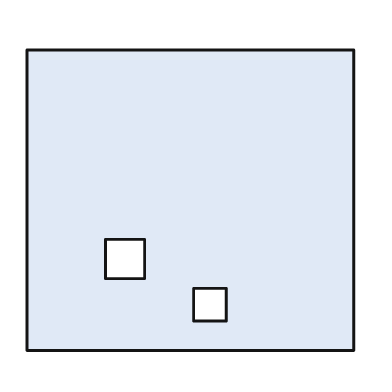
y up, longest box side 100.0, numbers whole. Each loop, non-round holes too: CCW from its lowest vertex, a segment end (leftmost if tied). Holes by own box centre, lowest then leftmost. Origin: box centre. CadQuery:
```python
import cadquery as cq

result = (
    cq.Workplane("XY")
    .moveTo(-50.0, -46.0)
    .lineTo(50.0, -46.0)
    .lineTo(50.0, 46.0)
    .lineTo(-50.0, 46.0)
    .close()
    .moveTo(1.0, -37.0)
    .lineTo(11.0, -37.0)
    .lineTo(11.0, -27.0)
    .lineTo(1.0, -27.0)
    .close()
    .moveTo(-26.0, -24.0)
    .lineTo(-14.0, -24.0)
    .lineTo(-14.0, -12.0)
    .lineTo(-26.0, -12.0)
    .close()
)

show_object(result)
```